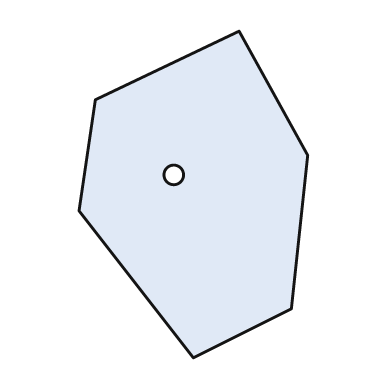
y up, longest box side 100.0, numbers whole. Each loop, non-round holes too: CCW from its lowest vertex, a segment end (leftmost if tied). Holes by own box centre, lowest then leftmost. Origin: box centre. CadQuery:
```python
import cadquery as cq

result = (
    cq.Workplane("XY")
    .moveTo(0.0, -50.0)
    .lineTo(30.0, -35.0)
    .lineTo(35.0, 12.0)
    .lineTo(14.0, 50.0)
    .lineTo(-30.0, 29.0)
    .lineTo(-35.0, -5.0)
    .close()
    .moveTo(-6.0, 6.0)
    .circle(3.0)
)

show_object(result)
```